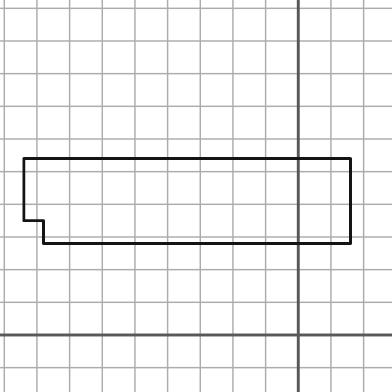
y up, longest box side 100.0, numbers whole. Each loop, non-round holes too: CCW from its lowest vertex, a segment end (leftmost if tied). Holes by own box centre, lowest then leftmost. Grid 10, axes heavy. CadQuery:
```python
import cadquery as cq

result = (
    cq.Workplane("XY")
    .moveTo(-78.0, 28.0)
    .lineTo(16.0, 28.0)
    .lineTo(16.0, 54.0)
    .lineTo(-84.0, 54.0)
    .lineTo(-84.0, 35.0)
    .lineTo(-78.0, 35.0)
    .close()
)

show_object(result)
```